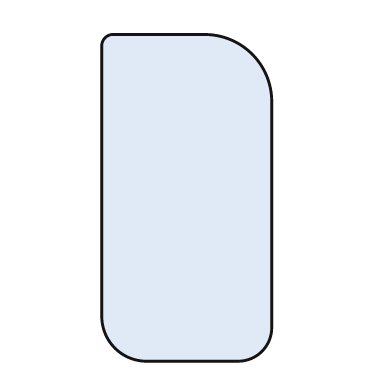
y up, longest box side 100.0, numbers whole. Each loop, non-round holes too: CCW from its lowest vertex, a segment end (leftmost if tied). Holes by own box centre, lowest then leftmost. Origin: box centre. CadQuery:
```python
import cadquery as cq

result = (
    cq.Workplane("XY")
    .moveTo(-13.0, -50.0)
    .lineTo(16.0, -50.0)
    .threePointArc((23.0, -47.0), (26.0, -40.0))
    .lineTo(26.0, 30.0)
    .threePointArc((20.0, 44.0), (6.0, 50.0))
    .lineTo(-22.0, 50.0)
    .threePointArc((-25.0, 49.0), (-26.0, 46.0))
    .lineTo(-26.0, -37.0)
    .threePointArc((-22.0, -46.0), (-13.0, -50.0))
    .close()
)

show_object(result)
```